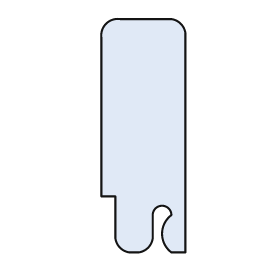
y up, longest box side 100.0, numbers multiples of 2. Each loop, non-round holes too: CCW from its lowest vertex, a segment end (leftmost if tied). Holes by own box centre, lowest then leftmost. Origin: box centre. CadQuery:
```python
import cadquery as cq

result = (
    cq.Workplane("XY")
    .moveTo(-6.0, -50.0)
    .lineTo(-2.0, -50.0)
    .threePointArc((2.0, -48.0), (4.0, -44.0))
    .lineTo(4.0, -34.0)
    .threePointArc((8.0, -30.0), (12.0, -34.0))
    .threePointArc((8.0, -42.0), (12.0, -50.0))
    .lineTo(18.0, -50.0)
    .lineTo(18.0, 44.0)
    .threePointArc((16.0, 48.0), (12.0, 50.0))
    .lineTo(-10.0, 50.0)
    .threePointArc((-16.0, 48.0), (-18.0, 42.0))
    .lineTo(-18.0, -26.0)
    .lineTo(-12.0, -26.0)
    .lineTo(-12.0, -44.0)
    .threePointArc((-10.0, -48.0), (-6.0, -50.0))
    .close()
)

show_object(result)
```